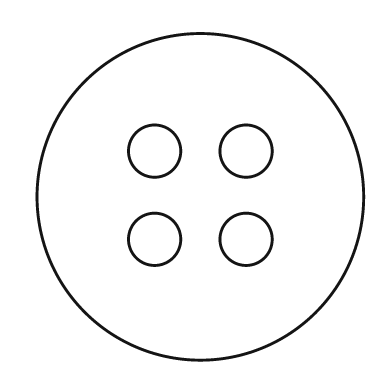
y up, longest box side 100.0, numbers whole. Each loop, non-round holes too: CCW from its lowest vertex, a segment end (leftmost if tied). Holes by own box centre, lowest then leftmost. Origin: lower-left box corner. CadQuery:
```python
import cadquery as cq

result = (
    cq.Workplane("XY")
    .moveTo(50.0, 50.0)
    .circle(50.0)
    .moveTo(36.0, 37.0)
    .circle(8.0)
    .moveTo(64.0, 37.0)
    .circle(8.0)
    .moveTo(36.0, 64.0)
    .circle(8.0)
    .moveTo(64.0, 64.0)
    .circle(8.0)
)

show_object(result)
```